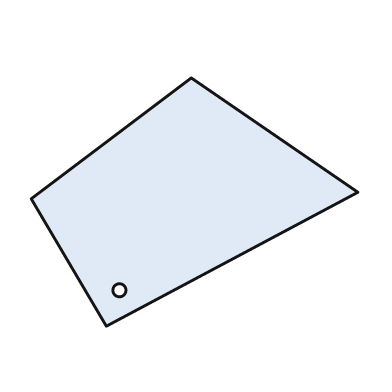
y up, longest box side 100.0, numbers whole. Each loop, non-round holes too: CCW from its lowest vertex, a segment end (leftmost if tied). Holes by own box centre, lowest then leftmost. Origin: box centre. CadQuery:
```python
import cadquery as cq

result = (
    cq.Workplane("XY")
    .moveTo(-27.0, -38.0)
    .lineTo(50.0, 3.0)
    .lineTo(-1.0, 38.0)
    .lineTo(-50.0, 1.0)
    .close()
    .moveTo(-23.0, -27.0)
    .circle(2.0)
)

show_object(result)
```